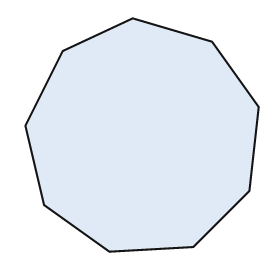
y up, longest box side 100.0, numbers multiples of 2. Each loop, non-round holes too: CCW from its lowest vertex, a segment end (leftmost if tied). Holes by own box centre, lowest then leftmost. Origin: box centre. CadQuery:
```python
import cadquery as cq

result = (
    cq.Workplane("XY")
    .moveTo(-14.0, -50.0)
    .lineTo(22.0, -48.0)
    .lineTo(46.0, -24.0)
    .lineTo(50.0, 12.0)
    .lineTo(30.0, 40.0)
    .lineTo(-4.0, 50.0)
    .lineTo(-34.0, 36.0)
    .lineTo(-50.0, 4.0)
    .lineTo(-42.0, -30.0)
    .close()
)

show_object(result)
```